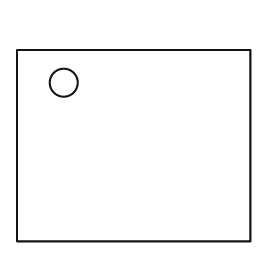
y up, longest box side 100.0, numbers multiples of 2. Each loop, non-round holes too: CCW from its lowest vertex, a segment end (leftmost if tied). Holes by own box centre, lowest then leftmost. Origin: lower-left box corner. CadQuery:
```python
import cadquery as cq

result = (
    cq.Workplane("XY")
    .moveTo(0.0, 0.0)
    .lineTo(100.0, 0.0)
    .lineTo(100.0, 82.0)
    .lineTo(0.0, 82.0)
    .close()
    .moveTo(20.0, 68.0)
    .circle(6.0)
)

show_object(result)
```